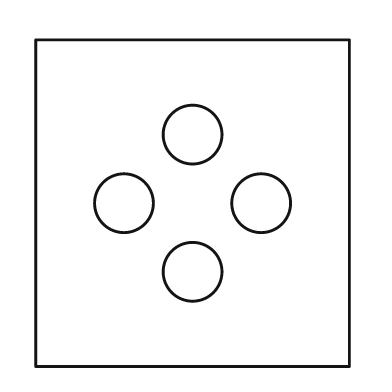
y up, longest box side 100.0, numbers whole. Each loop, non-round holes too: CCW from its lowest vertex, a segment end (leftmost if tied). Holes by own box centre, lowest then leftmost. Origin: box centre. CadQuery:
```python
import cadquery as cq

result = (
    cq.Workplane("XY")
    .moveTo(-48.0, -50.0)
    .lineTo(48.0, -50.0)
    .lineTo(48.0, 50.0)
    .lineTo(-48.0, 50.0)
    .close()
    .moveTo(0.0, -21.0)
    .circle(9.0)
    .moveTo(-21.0, 0.0)
    .circle(9.0)
    .moveTo(21.0, 0.0)
    .circle(9.0)
    .moveTo(0.0, 21.0)
    .circle(9.0)
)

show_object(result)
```